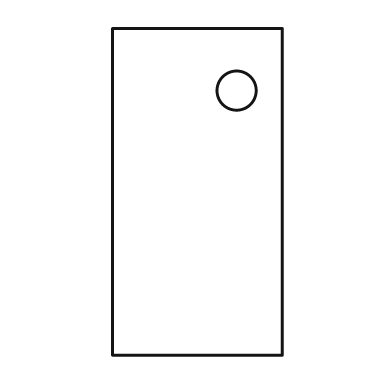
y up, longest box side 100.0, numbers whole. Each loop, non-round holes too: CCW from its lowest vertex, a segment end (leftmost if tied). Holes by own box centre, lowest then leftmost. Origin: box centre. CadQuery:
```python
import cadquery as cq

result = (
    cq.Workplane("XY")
    .moveTo(-26.0, -50.0)
    .lineTo(26.0, -50.0)
    .lineTo(26.0, 50.0)
    .lineTo(-26.0, 50.0)
    .close()
    .moveTo(12.0, 31.0)
    .circle(6.0)
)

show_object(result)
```